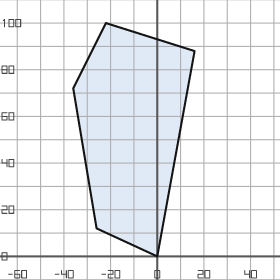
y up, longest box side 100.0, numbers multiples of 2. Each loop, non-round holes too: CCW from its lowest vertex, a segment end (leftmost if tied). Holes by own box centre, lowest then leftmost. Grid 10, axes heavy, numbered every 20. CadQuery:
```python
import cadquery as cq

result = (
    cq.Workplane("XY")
    .moveTo(0.0, 0.0)
    .lineTo(16.0, 88.0)
    .lineTo(-22.0, 100.0)
    .lineTo(-36.0, 72.0)
    .lineTo(-26.0, 12.0)
    .close()
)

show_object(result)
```